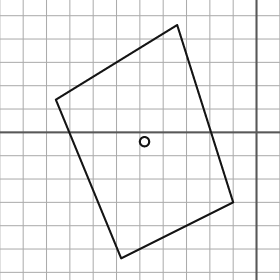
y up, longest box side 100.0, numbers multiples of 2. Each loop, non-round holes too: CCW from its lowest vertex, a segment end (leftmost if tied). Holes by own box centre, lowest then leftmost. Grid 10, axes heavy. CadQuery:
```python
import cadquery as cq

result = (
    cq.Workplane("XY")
    .moveTo(-58.0, -54.0)
    .lineTo(-10.0, -30.0)
    .lineTo(-34.0, 46.0)
    .lineTo(-86.0, 14.0)
    .close()
    .moveTo(-48.0, -4.0)
    .circle(2.0)
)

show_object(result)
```